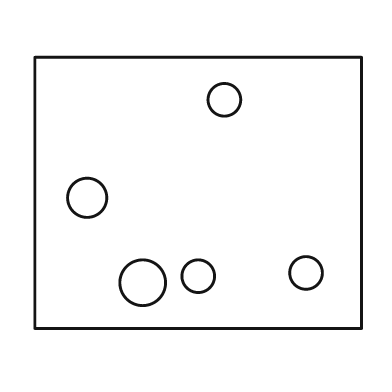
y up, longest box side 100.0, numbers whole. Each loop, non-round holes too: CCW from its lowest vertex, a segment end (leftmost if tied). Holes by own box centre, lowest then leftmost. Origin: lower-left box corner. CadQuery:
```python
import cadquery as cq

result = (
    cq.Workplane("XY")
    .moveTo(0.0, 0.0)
    .lineTo(100.0, 0.0)
    .lineTo(100.0, 83.0)
    .lineTo(0.0, 83.0)
    .close()
    .moveTo(33.0, 14.0)
    .circle(7.0)
    .moveTo(50.0, 16.0)
    .circle(5.0)
    .moveTo(83.0, 17.0)
    .circle(5.0)
    .moveTo(16.0, 40.0)
    .circle(6.0)
    .moveTo(58.0, 70.0)
    .circle(5.0)
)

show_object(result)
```